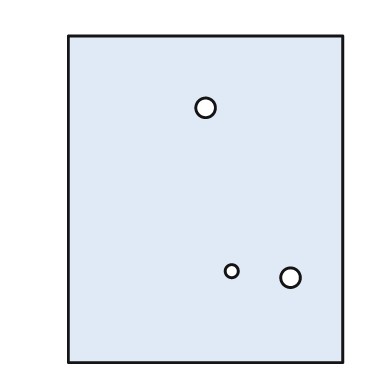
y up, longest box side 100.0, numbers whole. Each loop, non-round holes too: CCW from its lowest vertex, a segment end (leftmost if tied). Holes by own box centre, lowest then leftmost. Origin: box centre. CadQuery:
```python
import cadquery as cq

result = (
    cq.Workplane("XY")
    .moveTo(-42.0, -50.0)
    .lineTo(42.0, -50.0)
    .lineTo(42.0, 50.0)
    .lineTo(-42.0, 50.0)
    .close()
    .moveTo(26.0, -24.0)
    .circle(3.0)
    .moveTo(8.0, -22.0)
    .circle(2.0)
    .moveTo(0.0, 28.0)
    .circle(3.0)
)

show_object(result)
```